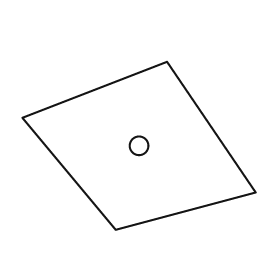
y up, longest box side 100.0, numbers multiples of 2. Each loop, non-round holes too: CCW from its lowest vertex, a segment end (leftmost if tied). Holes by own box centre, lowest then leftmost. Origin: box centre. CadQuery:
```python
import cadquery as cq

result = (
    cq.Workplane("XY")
    .moveTo(-10.0, -36.0)
    .lineTo(50.0, -20.0)
    .lineTo(12.0, 36.0)
    .lineTo(-50.0, 12.0)
    .close()
    .moveTo(0.0, 0.0)
    .circle(4.0)
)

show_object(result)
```